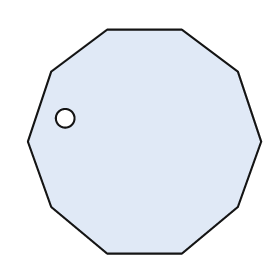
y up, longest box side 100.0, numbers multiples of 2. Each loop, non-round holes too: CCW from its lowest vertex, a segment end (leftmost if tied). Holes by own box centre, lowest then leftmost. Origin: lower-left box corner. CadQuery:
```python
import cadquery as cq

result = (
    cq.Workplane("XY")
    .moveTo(34.0, 0.0)
    .lineTo(66.0, 0.0)
    .lineTo(90.0, 20.0)
    .lineTo(100.0, 48.0)
    .lineTo(90.0, 78.0)
    .lineTo(66.0, 96.0)
    .lineTo(34.0, 96.0)
    .lineTo(10.0, 78.0)
    .lineTo(0.0, 48.0)
    .lineTo(10.0, 20.0)
    .close()
    .moveTo(16.0, 58.0)
    .circle(4.0)
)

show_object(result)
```